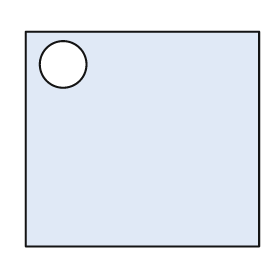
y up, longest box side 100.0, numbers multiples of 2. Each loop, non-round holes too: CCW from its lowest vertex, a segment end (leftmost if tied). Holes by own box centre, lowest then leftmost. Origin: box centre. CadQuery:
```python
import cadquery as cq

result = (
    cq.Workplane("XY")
    .moveTo(-50.0, -46.0)
    .lineTo(50.0, -46.0)
    .lineTo(50.0, 46.0)
    .lineTo(-50.0, 46.0)
    .close()
    .moveTo(-34.0, 32.0)
    .circle(10.0)
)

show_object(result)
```